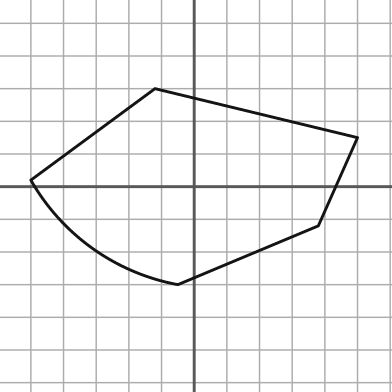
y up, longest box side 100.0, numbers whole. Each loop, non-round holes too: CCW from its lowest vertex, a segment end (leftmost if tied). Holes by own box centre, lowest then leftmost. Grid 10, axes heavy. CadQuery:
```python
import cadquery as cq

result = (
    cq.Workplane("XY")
    .moveTo(-5.0, -30.0)
    .lineTo(38.0, -12.0)
    .lineTo(50.0, 15.0)
    .lineTo(-12.0, 30.0)
    .lineTo(-50.0, 2.0)
    .threePointArc((-31.0, -19.0), (-5.0, -30.0))
    .close()
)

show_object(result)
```